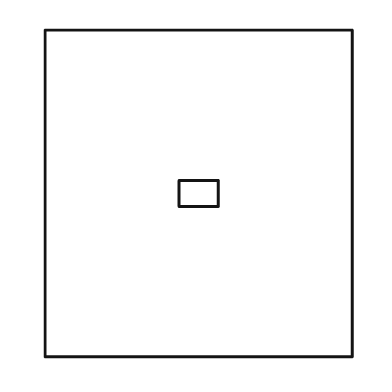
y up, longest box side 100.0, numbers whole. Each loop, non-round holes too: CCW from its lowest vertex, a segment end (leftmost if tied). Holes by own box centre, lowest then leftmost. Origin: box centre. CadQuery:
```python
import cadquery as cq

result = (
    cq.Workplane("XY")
    .moveTo(-47.0, -50.0)
    .lineTo(47.0, -50.0)
    .lineTo(47.0, 50.0)
    .lineTo(-47.0, 50.0)
    .close()
    .moveTo(-6.0, -4.0)
    .lineTo(6.0, -4.0)
    .lineTo(6.0, 4.0)
    .lineTo(-6.0, 4.0)
    .close()
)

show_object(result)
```